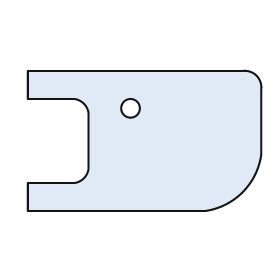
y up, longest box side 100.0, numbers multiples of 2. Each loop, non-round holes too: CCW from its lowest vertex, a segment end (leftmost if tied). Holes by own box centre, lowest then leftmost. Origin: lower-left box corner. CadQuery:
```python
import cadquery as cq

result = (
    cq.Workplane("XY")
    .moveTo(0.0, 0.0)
    .lineTo(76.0, 0.0)
    .threePointArc((92.0, 8.0), (100.0, 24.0))
    .lineTo(100.0, 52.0)
    .threePointArc((98.0, 58.0), (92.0, 60.0))
    .lineTo(0.0, 60.0)
    .lineTo(0.0, 48.0)
    .lineTo(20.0, 48.0)
    .threePointArc((24.0, 46.0), (26.0, 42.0))
    .lineTo(26.0, 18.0)
    .threePointArc((24.0, 14.0), (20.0, 12.0))
    .lineTo(0.0, 12.0)
    .close()
    .moveTo(44.0, 44.0)
    .circle(4.0)
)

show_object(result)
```